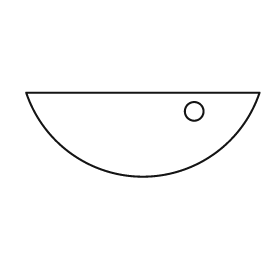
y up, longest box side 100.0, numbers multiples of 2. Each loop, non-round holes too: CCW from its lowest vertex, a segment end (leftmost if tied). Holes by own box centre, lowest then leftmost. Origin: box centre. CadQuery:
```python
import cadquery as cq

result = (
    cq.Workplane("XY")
    .moveTo(-50.0, 18.0)
    .threePointArc((0.0, -18.0), (50.0, 18.0))
    .close()
    .moveTo(22.0, 10.0)
    .circle(4.0)
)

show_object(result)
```